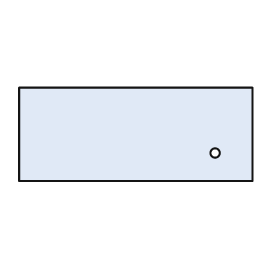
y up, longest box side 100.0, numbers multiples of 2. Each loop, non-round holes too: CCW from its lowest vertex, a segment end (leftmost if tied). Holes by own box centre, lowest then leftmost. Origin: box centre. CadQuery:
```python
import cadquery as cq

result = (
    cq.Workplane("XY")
    .moveTo(-50.0, -20.0)
    .lineTo(50.0, -20.0)
    .lineTo(50.0, 20.0)
    .lineTo(-50.0, 20.0)
    .close()
    .moveTo(34.0, -8.0)
    .circle(2.0)
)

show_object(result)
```